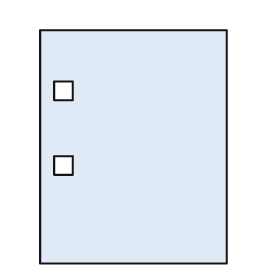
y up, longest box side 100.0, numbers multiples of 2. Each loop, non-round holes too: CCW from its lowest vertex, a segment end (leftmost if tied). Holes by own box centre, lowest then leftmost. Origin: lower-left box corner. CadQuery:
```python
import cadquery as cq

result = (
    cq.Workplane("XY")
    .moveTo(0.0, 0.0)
    .lineTo(80.0, 0.0)
    .lineTo(80.0, 100.0)
    .lineTo(0.0, 100.0)
    .close()
    .moveTo(6.0, 38.0)
    .lineTo(14.0, 38.0)
    .lineTo(14.0, 46.0)
    .lineTo(6.0, 46.0)
    .close()
    .moveTo(6.0, 70.0)
    .lineTo(14.0, 70.0)
    .lineTo(14.0, 78.0)
    .lineTo(6.0, 78.0)
    .close()
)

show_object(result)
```